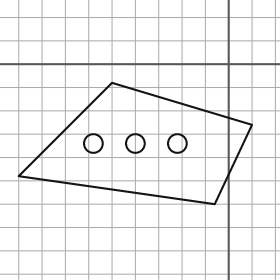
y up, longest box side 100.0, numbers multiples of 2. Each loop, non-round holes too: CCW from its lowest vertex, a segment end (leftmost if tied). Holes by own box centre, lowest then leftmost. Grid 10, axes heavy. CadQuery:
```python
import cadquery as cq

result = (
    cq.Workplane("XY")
    .moveTo(-6.0, -60.0)
    .lineTo(10.0, -26.0)
    .lineTo(-50.0, -8.0)
    .lineTo(-90.0, -48.0)
    .close()
    .moveTo(-58.0, -34.0)
    .circle(4.0)
    .moveTo(-40.0, -34.0)
    .circle(4.0)
    .moveTo(-22.0, -34.0)
    .circle(4.0)
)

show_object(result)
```